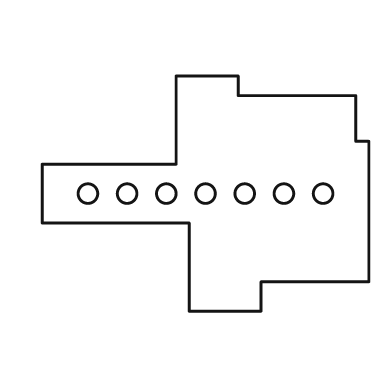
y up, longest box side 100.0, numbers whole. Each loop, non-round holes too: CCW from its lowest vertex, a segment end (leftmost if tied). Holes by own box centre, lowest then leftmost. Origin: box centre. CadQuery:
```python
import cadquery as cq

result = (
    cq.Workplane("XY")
    .moveTo(-5.0, -36.0)
    .lineTo(17.0, -36.0)
    .lineTo(17.0, -27.0)
    .lineTo(50.0, -27.0)
    .lineTo(50.0, 16.0)
    .lineTo(46.0, 16.0)
    .lineTo(46.0, 30.0)
    .lineTo(10.0, 30.0)
    .lineTo(10.0, 36.0)
    .lineTo(-9.0, 36.0)
    .lineTo(-9.0, 9.0)
    .lineTo(-50.0, 9.0)
    .lineTo(-50.0, -9.0)
    .lineTo(-5.0, -9.0)
    .close()
    .moveTo(-36.0, 0.0)
    .circle(3.0)
    .moveTo(-24.0, 0.0)
    .circle(3.0)
    .moveTo(-12.0, 0.0)
    .circle(3.0)
    .moveTo(0.0, 0.0)
    .circle(3.0)
    .moveTo(12.0, 0.0)
    .circle(3.0)
    .moveTo(24.0, 0.0)
    .circle(3.0)
    .moveTo(36.0, 0.0)
    .circle(3.0)
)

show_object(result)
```